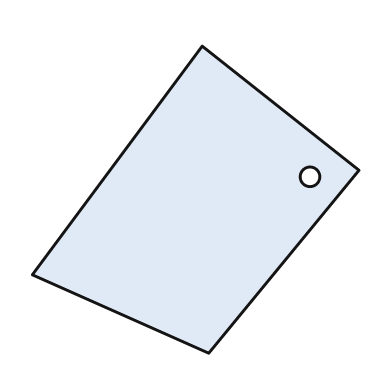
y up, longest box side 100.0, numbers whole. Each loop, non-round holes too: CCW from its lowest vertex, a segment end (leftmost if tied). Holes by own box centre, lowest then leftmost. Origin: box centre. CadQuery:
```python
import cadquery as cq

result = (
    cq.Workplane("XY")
    .moveTo(4.0, -47.0)
    .lineTo(50.0, 9.0)
    .lineTo(2.0, 47.0)
    .lineTo(-50.0, -23.0)
    .close()
    .moveTo(35.0, 7.0)
    .circle(3.0)
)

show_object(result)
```